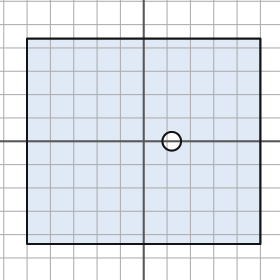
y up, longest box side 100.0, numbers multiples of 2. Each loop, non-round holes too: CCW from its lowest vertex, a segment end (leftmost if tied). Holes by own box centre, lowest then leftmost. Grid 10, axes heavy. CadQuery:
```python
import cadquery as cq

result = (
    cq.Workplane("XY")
    .moveTo(-50.0, -44.0)
    .lineTo(50.0, -44.0)
    .lineTo(50.0, 44.0)
    .lineTo(-50.0, 44.0)
    .close()
    .moveTo(12.0, 0.0)
    .circle(4.0)
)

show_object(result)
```